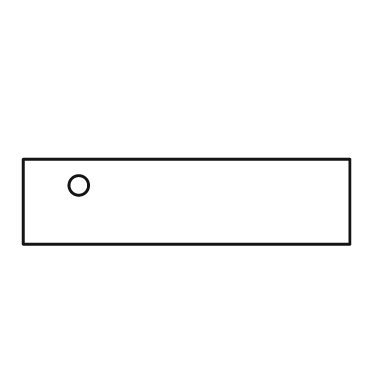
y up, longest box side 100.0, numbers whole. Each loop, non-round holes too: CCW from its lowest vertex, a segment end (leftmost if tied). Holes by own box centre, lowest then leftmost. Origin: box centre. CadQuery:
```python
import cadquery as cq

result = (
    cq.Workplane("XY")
    .moveTo(-50.0, -13.0)
    .lineTo(50.0, -13.0)
    .lineTo(50.0, 13.0)
    .lineTo(-50.0, 13.0)
    .close()
    .moveTo(-33.0, 5.0)
    .circle(3.0)
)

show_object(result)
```